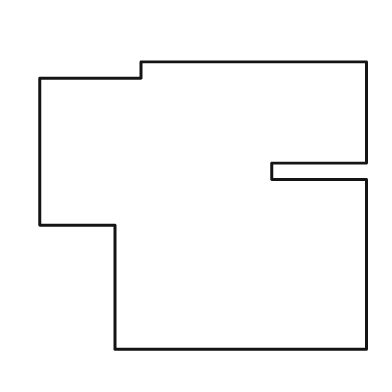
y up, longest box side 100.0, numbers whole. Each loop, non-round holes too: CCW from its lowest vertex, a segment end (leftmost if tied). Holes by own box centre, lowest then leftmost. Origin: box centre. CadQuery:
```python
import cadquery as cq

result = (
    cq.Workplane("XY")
    .moveTo(-27.0, -44.0)
    .lineTo(50.0, -44.0)
    .lineTo(50.0, 8.0)
    .lineTo(21.0, 8.0)
    .lineTo(21.0, 13.0)
    .lineTo(50.0, 13.0)
    .lineTo(50.0, 44.0)
    .lineTo(-19.0, 44.0)
    .lineTo(-19.0, 39.0)
    .lineTo(-50.0, 39.0)
    .lineTo(-50.0, -6.0)
    .lineTo(-27.0, -6.0)
    .close()
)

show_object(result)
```